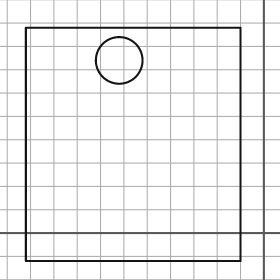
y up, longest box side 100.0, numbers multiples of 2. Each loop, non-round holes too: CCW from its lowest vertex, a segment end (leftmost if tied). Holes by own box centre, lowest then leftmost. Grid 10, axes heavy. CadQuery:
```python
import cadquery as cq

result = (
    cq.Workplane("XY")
    .moveTo(-102.0, -12.0)
    .lineTo(-10.0, -12.0)
    .lineTo(-10.0, 88.0)
    .lineTo(-102.0, 88.0)
    .close()
    .moveTo(-62.0, 74.0)
    .circle(10.0)
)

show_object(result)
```